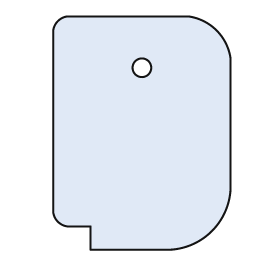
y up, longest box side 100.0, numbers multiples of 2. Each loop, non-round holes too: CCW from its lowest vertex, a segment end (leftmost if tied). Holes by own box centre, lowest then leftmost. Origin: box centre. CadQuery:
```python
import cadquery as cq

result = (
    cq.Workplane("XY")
    .moveTo(-22.0, -50.0)
    .lineTo(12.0, -50.0)
    .threePointArc((30.0, -42.0), (38.0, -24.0))
    .lineTo(38.0, 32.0)
    .threePointArc((32.0, 44.0), (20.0, 50.0))
    .lineTo(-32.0, 50.0)
    .threePointArc((-36.0, 48.0), (-38.0, 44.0))
    .lineTo(-38.0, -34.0)
    .threePointArc((-36.0, -38.0), (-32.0, -40.0))
    .lineTo(-22.0, -40.0)
    .close()
    .moveTo(0.0, 28.0)
    .circle(4.0)
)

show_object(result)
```